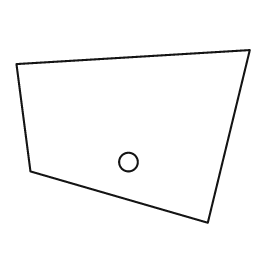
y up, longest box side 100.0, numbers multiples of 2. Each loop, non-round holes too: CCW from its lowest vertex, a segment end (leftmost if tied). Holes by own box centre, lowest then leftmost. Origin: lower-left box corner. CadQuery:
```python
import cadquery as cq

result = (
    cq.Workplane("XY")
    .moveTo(82.0, 0.0)
    .lineTo(100.0, 74.0)
    .lineTo(0.0, 68.0)
    .lineTo(6.0, 22.0)
    .close()
    .moveTo(48.0, 26.0)
    .circle(4.0)
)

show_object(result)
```